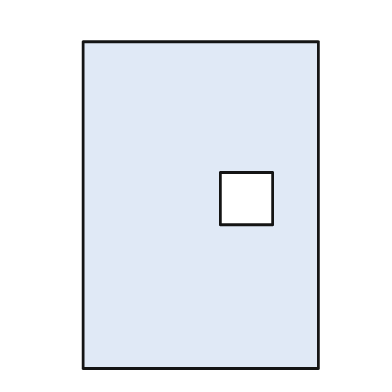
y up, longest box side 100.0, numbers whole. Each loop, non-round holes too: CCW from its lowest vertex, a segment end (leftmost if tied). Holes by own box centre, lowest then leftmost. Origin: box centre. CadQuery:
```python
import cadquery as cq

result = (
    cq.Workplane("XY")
    .moveTo(-36.0, -50.0)
    .lineTo(36.0, -50.0)
    .lineTo(36.0, 50.0)
    .lineTo(-36.0, 50.0)
    .close()
    .moveTo(6.0, -6.0)
    .lineTo(22.0, -6.0)
    .lineTo(22.0, 10.0)
    .lineTo(6.0, 10.0)
    .close()
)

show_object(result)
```